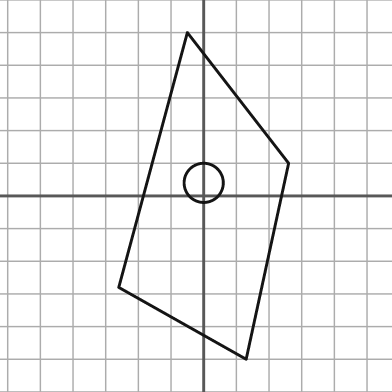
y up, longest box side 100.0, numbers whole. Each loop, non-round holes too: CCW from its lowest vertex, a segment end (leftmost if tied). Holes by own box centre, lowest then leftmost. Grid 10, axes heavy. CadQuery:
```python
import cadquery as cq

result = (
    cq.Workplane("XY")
    .moveTo(13.0, -50.0)
    .lineTo(26.0, 10.0)
    .lineTo(-5.0, 50.0)
    .lineTo(-26.0, -28.0)
    .close()
    .moveTo(0.0, 4.0)
    .circle(6.0)
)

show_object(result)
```